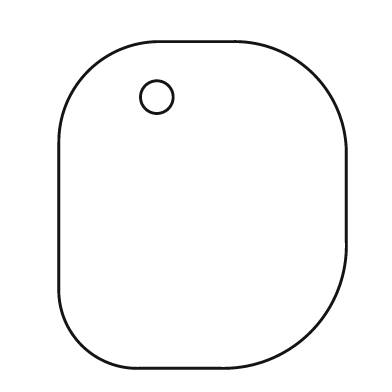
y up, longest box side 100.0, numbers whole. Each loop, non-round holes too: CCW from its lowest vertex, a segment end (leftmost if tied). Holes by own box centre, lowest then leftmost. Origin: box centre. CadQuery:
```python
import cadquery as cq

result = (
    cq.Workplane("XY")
    .moveTo(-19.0, -50.0)
    .lineTo(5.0, -50.0)
    .threePointArc((33.0, -39.0), (44.0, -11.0))
    .lineTo(44.0, 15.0)
    .threePointArc((34.0, 40.0), (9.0, 50.0))
    .lineTo(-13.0, 50.0)
    .threePointArc((-35.0, 41.0), (-44.0, 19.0))
    .lineTo(-44.0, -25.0)
    .threePointArc((-37.0, -43.0), (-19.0, -50.0))
    .close()
    .moveTo(-14.0, 33.0)
    .circle(5.0)
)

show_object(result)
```